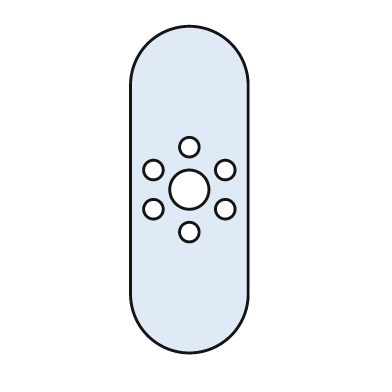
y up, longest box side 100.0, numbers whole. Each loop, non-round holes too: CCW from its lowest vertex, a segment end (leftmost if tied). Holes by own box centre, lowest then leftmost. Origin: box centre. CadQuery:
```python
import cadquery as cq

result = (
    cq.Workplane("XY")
    .moveTo(-18.0, -32.0)
    .threePointArc((0.0, -50.0), (18.0, -32.0))
    .lineTo(18.0, 32.0)
    .threePointArc((0.0, 50.0), (-18.0, 32.0))
    .close()
    .moveTo(0.0, -13.0)
    .circle(3.0)
    .moveTo(-11.0, -6.0)
    .circle(3.0)
    .moveTo(11.0, -6.0)
    .circle(3.0)
    .moveTo(0.0, 0.0)
    .circle(6.0)
    .moveTo(-11.0, 6.0)
    .circle(3.0)
    .moveTo(11.0, 6.0)
    .circle(3.0)
    .moveTo(0.0, 13.0)
    .circle(3.0)
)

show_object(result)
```